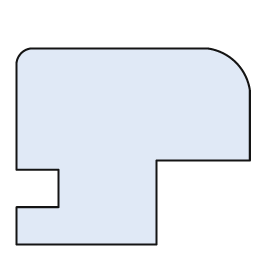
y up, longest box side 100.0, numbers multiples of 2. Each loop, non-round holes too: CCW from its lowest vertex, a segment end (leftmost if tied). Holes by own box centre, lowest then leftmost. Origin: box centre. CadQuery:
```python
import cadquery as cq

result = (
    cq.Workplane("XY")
    .moveTo(-50.0, -42.0)
    .lineTo(10.0, -42.0)
    .lineTo(10.0, -6.0)
    .lineTo(50.0, -6.0)
    .lineTo(50.0, 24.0)
    .threePointArc((44.0, 36.0), (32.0, 42.0))
    .lineTo(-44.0, 42.0)
    .threePointArc((-48.0, 40.0), (-50.0, 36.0))
    .lineTo(-50.0, -10.0)
    .lineTo(-32.0, -10.0)
    .lineTo(-32.0, -26.0)
    .lineTo(-50.0, -26.0)
    .close()
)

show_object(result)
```